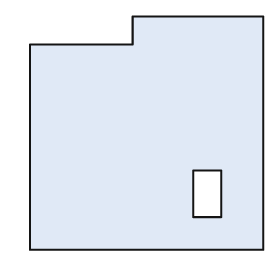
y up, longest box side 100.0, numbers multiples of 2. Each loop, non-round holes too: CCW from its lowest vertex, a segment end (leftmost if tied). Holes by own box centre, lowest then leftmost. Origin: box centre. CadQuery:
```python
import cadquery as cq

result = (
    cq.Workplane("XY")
    .moveTo(-50.0, -50.0)
    .lineTo(50.0, -50.0)
    .lineTo(50.0, 50.0)
    .lineTo(-6.0, 50.0)
    .lineTo(-6.0, 38.0)
    .lineTo(-50.0, 38.0)
    .close()
    .moveTo(20.0, -36.0)
    .lineTo(32.0, -36.0)
    .lineTo(32.0, -16.0)
    .lineTo(20.0, -16.0)
    .close()
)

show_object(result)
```